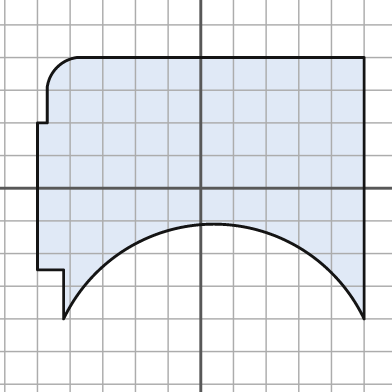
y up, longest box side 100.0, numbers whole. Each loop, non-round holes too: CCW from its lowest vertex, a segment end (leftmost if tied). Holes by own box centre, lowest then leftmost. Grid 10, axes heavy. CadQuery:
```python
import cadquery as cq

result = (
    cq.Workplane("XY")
    .moveTo(-42.0, -40.0)
    .threePointArc((4.0, -11.0), (50.0, -40.0))
    .lineTo(50.0, 40.0)
    .lineTo(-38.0, 40.0)
    .threePointArc((-44.0, 37.0), (-47.0, 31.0))
    .lineTo(-47.0, 20.0)
    .lineTo(-50.0, 20.0)
    .lineTo(-50.0, -25.0)
    .lineTo(-42.0, -25.0)
    .close()
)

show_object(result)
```